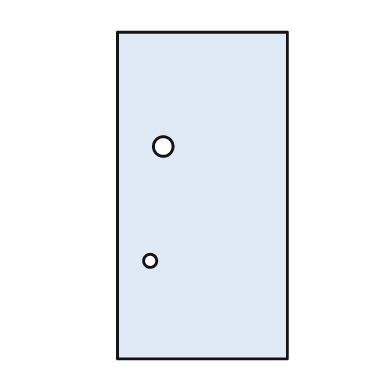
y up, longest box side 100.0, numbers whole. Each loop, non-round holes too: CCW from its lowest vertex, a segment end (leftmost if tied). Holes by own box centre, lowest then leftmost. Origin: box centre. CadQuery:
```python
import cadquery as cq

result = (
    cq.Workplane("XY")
    .moveTo(-26.0, -50.0)
    .lineTo(26.0, -50.0)
    .lineTo(26.0, 50.0)
    .lineTo(-26.0, 50.0)
    .close()
    .moveTo(-16.0, -20.0)
    .circle(2.0)
    .moveTo(-12.0, 15.0)
    .circle(3.0)
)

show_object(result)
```